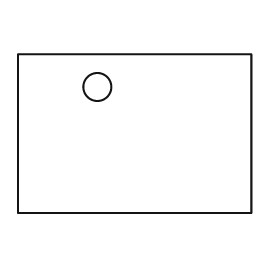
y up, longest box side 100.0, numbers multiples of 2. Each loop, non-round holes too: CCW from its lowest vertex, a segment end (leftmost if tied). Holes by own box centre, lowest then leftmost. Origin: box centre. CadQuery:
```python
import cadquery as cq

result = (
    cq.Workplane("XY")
    .moveTo(-50.0, -34.0)
    .lineTo(50.0, -34.0)
    .lineTo(50.0, 34.0)
    .lineTo(-50.0, 34.0)
    .close()
    .moveTo(-16.0, 20.0)
    .circle(6.0)
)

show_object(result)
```